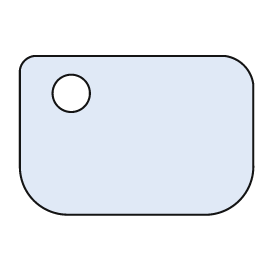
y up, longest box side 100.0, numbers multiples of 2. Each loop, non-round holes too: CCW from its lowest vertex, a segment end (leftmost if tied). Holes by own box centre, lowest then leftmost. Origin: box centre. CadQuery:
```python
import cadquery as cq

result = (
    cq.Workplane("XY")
    .moveTo(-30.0, -34.0)
    .lineTo(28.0, -34.0)
    .threePointArc((44.0, -28.0), (50.0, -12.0))
    .lineTo(50.0, 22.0)
    .threePointArc((46.0, 30.0), (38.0, 34.0))
    .lineTo(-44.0, 34.0)
    .threePointArc((-48.0, 32.0), (-50.0, 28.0))
    .lineTo(-50.0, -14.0)
    .threePointArc((-44.0, -28.0), (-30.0, -34.0))
    .close()
    .moveTo(-28.0, 18.0)
    .circle(8.0)
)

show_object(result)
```